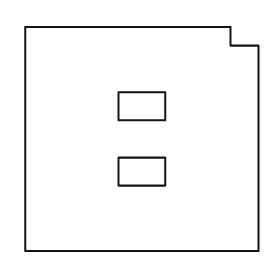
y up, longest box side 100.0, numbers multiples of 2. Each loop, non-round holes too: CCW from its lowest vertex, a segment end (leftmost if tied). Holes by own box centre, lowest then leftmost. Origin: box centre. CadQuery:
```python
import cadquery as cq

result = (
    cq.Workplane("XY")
    .moveTo(-50.0, -48.0)
    .lineTo(50.0, -48.0)
    .lineTo(50.0, 40.0)
    .lineTo(38.0, 40.0)
    .lineTo(38.0, 48.0)
    .lineTo(-50.0, 48.0)
    .close()
    .moveTo(-10.0, -20.0)
    .lineTo(10.0, -20.0)
    .lineTo(10.0, -8.0)
    .lineTo(-10.0, -8.0)
    .close()
    .moveTo(-10.0, 8.0)
    .lineTo(10.0, 8.0)
    .lineTo(10.0, 20.0)
    .lineTo(-10.0, 20.0)
    .close()
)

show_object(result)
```